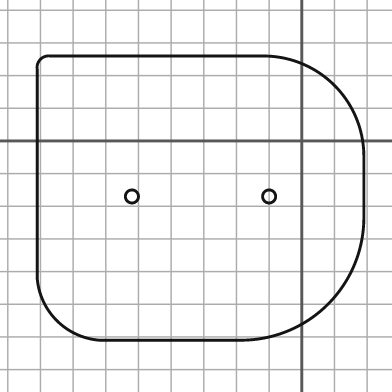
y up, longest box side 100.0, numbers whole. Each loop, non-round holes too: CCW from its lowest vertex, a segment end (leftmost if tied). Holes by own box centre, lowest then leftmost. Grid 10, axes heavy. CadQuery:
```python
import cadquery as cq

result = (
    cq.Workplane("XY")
    .moveTo(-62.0, -61.0)
    .lineTo(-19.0, -61.0)
    .threePointArc((8.0, -50.0), (19.0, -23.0))
    .lineTo(19.0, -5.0)
    .threePointArc((10.0, 17.0), (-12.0, 26.0))
    .lineTo(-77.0, 26.0)
    .threePointArc((-80.0, 25.0), (-81.0, 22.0))
    .lineTo(-81.0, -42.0)
    .threePointArc((-75.0, -55.0), (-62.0, -61.0))
    .close()
    .moveTo(-52.0, -17.0)
    .circle(2.0)
    .moveTo(-10.0, -17.0)
    .circle(2.0)
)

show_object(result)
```